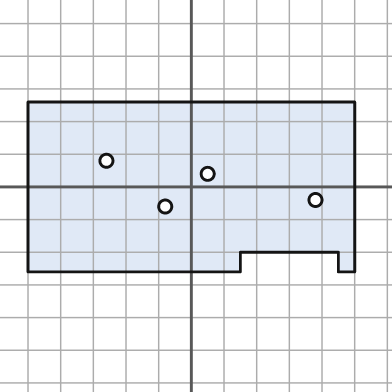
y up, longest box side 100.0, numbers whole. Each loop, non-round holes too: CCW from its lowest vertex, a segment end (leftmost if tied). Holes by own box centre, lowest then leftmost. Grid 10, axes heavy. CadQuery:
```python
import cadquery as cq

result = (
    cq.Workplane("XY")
    .moveTo(-50.0, -26.0)
    .lineTo(15.0, -26.0)
    .lineTo(15.0, -20.0)
    .lineTo(45.0, -20.0)
    .lineTo(45.0, -26.0)
    .lineTo(50.0, -26.0)
    .lineTo(50.0, 26.0)
    .lineTo(-50.0, 26.0)
    .close()
    .moveTo(-8.0, -6.0)
    .circle(2.0)
    .moveTo(38.0, -4.0)
    .circle(2.0)
    .moveTo(5.0, 4.0)
    .circle(2.0)
    .moveTo(-26.0, 8.0)
    .circle(2.0)
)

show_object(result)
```